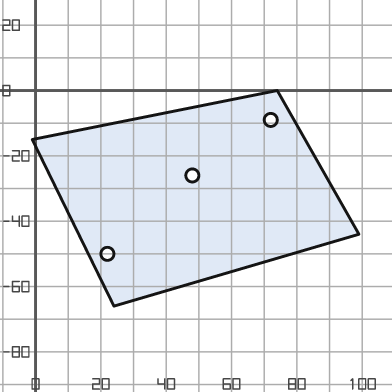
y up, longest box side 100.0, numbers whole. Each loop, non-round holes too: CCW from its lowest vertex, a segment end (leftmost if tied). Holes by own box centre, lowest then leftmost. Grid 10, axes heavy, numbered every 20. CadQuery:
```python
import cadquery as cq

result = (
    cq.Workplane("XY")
    .moveTo(24.0, -66.0)
    .lineTo(99.0, -44.0)
    .lineTo(74.0, 0.0)
    .lineTo(-1.0, -15.0)
    .close()
    .moveTo(22.0, -50.0)
    .circle(2.0)
    .moveTo(48.0, -26.0)
    .circle(2.0)
    .moveTo(72.0, -9.0)
    .circle(2.0)
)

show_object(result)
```